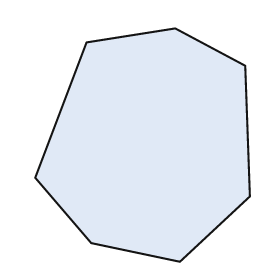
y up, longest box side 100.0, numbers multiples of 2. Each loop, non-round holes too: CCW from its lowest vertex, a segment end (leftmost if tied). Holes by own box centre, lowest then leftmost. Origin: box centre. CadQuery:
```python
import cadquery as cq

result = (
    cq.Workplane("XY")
    .moveTo(16.0, -50.0)
    .lineTo(46.0, -22.0)
    .lineTo(44.0, 34.0)
    .lineTo(14.0, 50.0)
    .lineTo(-24.0, 44.0)
    .lineTo(-46.0, -14.0)
    .lineTo(-22.0, -42.0)
    .close()
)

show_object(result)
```